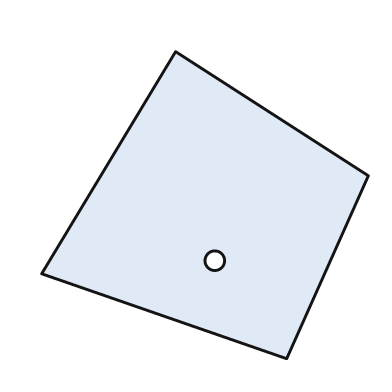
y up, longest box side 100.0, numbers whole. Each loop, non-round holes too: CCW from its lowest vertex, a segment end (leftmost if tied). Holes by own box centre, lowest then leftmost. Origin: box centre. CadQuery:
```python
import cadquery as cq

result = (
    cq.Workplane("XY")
    .moveTo(25.0, -47.0)
    .lineTo(50.0, 9.0)
    .lineTo(-9.0, 47.0)
    .lineTo(-50.0, -21.0)
    .close()
    .moveTo(3.0, -17.0)
    .circle(3.0)
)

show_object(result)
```